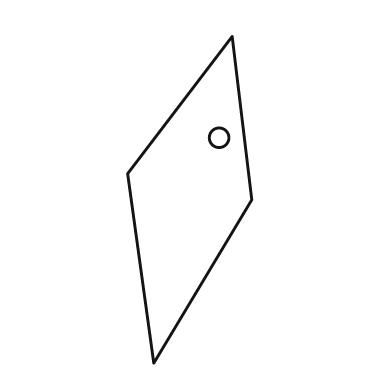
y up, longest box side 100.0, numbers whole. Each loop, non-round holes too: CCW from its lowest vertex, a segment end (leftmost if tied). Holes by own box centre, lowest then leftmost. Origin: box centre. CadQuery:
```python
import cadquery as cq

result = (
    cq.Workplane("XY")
    .moveTo(-11.0, -50.0)
    .lineTo(19.0, 0.0)
    .lineTo(13.0, 50.0)
    .lineTo(-19.0, 8.0)
    .close()
    .moveTo(9.0, 19.0)
    .circle(3.0)
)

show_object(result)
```